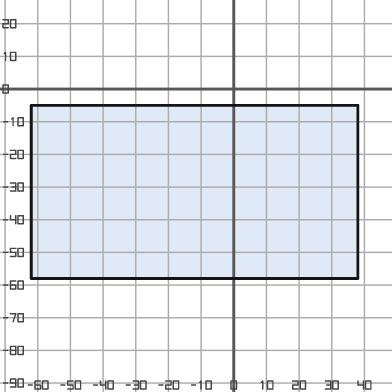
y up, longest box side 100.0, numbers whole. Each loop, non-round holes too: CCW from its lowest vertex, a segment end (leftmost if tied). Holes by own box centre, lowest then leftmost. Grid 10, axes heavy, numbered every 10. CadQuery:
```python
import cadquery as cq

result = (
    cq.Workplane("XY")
    .moveTo(-62.0, -58.0)
    .lineTo(38.0, -58.0)
    .lineTo(38.0, -5.0)
    .lineTo(-62.0, -5.0)
    .close()
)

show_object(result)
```